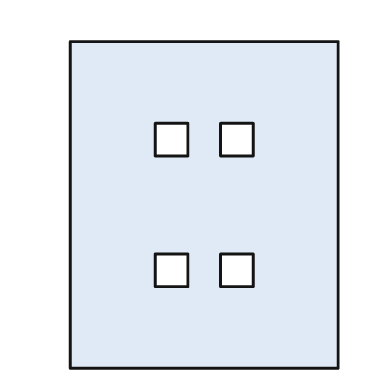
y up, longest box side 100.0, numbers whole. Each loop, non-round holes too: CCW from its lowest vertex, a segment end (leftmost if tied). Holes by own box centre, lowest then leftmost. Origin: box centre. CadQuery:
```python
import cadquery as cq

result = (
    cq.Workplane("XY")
    .moveTo(-41.0, -50.0)
    .lineTo(41.0, -50.0)
    .lineTo(41.0, 50.0)
    .lineTo(-41.0, 50.0)
    .close()
    .moveTo(-15.0, -25.0)
    .lineTo(-5.0, -25.0)
    .lineTo(-5.0, -15.0)
    .lineTo(-15.0, -15.0)
    .close()
    .moveTo(5.0, -25.0)
    .lineTo(15.0, -25.0)
    .lineTo(15.0, -15.0)
    .lineTo(5.0, -15.0)
    .close()
    .moveTo(-15.0, 15.0)
    .lineTo(-5.0, 15.0)
    .lineTo(-5.0, 25.0)
    .lineTo(-15.0, 25.0)
    .close()
    .moveTo(5.0, 15.0)
    .lineTo(15.0, 15.0)
    .lineTo(15.0, 25.0)
    .lineTo(5.0, 25.0)
    .close()
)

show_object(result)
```